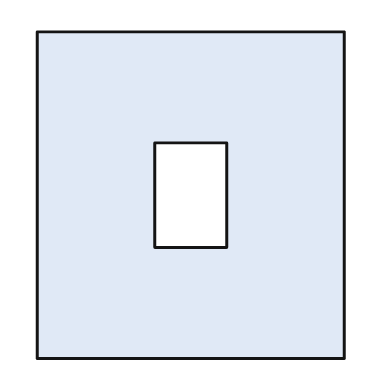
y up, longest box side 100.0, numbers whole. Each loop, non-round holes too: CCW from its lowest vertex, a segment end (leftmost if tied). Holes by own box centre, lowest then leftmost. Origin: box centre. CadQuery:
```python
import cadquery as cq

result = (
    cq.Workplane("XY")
    .moveTo(-47.0, -50.0)
    .lineTo(47.0, -50.0)
    .lineTo(47.0, 50.0)
    .lineTo(-47.0, 50.0)
    .close()
    .moveTo(-11.0, -16.0)
    .lineTo(11.0, -16.0)
    .lineTo(11.0, 16.0)
    .lineTo(-11.0, 16.0)
    .close()
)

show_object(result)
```